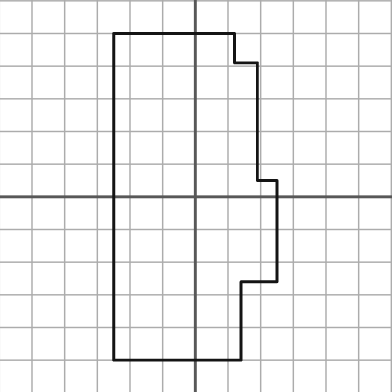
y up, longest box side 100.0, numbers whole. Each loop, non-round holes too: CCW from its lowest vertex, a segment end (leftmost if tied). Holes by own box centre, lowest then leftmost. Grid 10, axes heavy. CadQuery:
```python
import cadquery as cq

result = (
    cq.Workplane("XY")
    .moveTo(-25.0, -50.0)
    .lineTo(14.0, -50.0)
    .lineTo(14.0, -26.0)
    .lineTo(25.0, -26.0)
    .lineTo(25.0, 5.0)
    .lineTo(19.0, 5.0)
    .lineTo(19.0, 41.0)
    .lineTo(12.0, 41.0)
    .lineTo(12.0, 50.0)
    .lineTo(-25.0, 50.0)
    .close()
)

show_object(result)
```